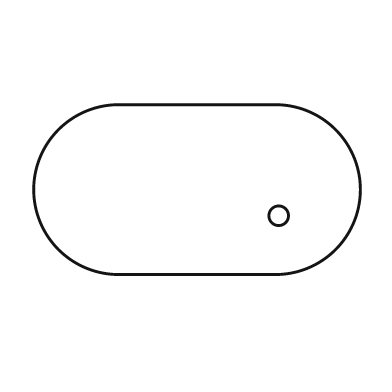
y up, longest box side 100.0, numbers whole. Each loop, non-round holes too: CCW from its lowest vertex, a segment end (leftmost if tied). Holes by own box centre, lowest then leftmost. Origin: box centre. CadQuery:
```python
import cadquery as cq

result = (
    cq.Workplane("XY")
    .moveTo(-24.0, -26.0)
    .lineTo(24.0, -26.0)
    .threePointArc((50.0, 0.0), (24.0, 26.0))
    .lineTo(-24.0, 26.0)
    .threePointArc((-50.0, 0.0), (-24.0, -26.0))
    .close()
    .moveTo(25.0, -8.0)
    .circle(3.0)
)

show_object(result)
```